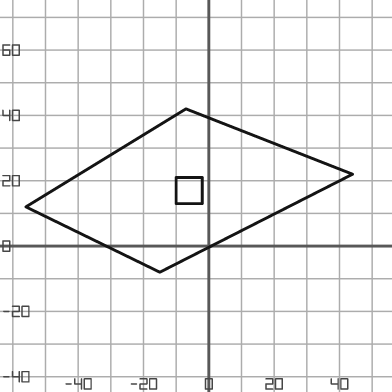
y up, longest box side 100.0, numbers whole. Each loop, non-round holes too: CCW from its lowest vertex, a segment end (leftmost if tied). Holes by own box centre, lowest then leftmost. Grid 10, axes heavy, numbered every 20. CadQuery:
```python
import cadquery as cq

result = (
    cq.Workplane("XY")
    .moveTo(-15.0, -8.0)
    .lineTo(44.0, 22.0)
    .lineTo(-7.0, 42.0)
    .lineTo(-56.0, 12.0)
    .close()
    .moveTo(-10.0, 13.0)
    .lineTo(-2.0, 13.0)
    .lineTo(-2.0, 21.0)
    .lineTo(-10.0, 21.0)
    .close()
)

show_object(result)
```